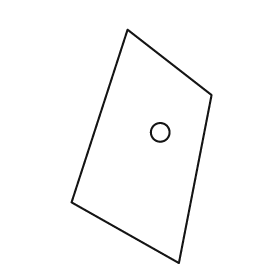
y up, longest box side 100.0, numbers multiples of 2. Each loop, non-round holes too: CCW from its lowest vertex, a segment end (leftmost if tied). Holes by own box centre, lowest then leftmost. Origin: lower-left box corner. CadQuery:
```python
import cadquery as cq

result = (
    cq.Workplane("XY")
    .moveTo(46.0, 0.0)
    .lineTo(60.0, 72.0)
    .lineTo(24.0, 100.0)
    .lineTo(0.0, 26.0)
    .close()
    .moveTo(38.0, 56.0)
    .circle(4.0)
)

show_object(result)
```